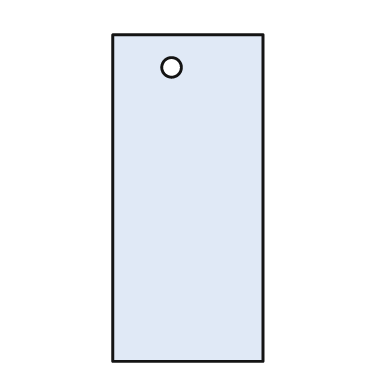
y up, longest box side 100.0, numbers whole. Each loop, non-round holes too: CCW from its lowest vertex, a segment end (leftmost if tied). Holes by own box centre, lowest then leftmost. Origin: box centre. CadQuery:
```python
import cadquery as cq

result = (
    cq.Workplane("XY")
    .moveTo(-23.0, -50.0)
    .lineTo(23.0, -50.0)
    .lineTo(23.0, 50.0)
    .lineTo(-23.0, 50.0)
    .close()
    .moveTo(-5.0, 40.0)
    .circle(3.0)
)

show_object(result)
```